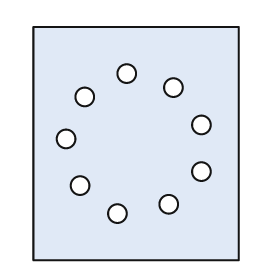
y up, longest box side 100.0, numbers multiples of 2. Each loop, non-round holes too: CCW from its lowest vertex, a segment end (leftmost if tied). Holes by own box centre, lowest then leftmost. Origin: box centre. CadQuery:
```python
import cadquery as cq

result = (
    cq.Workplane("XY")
    .moveTo(-44.0, -50.0)
    .lineTo(44.0, -50.0)
    .lineTo(44.0, 50.0)
    .lineTo(-44.0, 50.0)
    .close()
    .moveTo(-8.0, -30.0)
    .circle(4.0)
    .moveTo(14.0, -26.0)
    .circle(4.0)
    .moveTo(-24.0, -18.0)
    .circle(4.0)
    .moveTo(28.0, -12.0)
    .circle(4.0)
    .moveTo(-30.0, 2.0)
    .circle(4.0)
    .moveTo(28.0, 8.0)
    .circle(4.0)
    .moveTo(-22.0, 20.0)
    .circle(4.0)
    .moveTo(16.0, 24.0)
    .circle(4.0)
    .moveTo(-4.0, 30.0)
    .circle(4.0)
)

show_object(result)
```